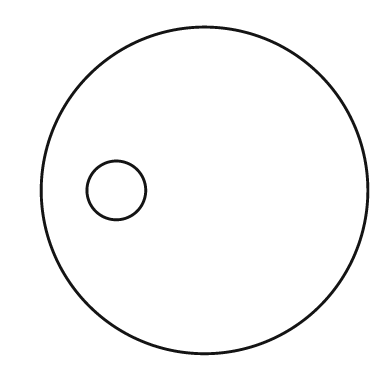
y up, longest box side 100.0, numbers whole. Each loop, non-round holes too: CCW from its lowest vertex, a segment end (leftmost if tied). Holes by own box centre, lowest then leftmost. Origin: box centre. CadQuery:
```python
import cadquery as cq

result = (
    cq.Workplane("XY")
    .moveTo(0.0, 0.0)
    .circle(50.0)
    .moveTo(-27.0, 0.0)
    .circle(9.0)
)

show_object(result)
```